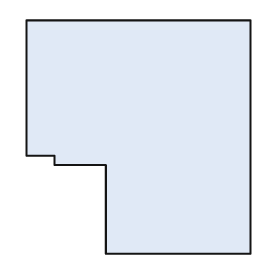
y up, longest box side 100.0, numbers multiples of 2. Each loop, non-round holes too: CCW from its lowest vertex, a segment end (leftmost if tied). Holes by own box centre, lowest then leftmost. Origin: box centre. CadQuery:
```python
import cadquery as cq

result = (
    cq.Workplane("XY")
    .moveTo(-14.0, -50.0)
    .lineTo(48.0, -50.0)
    .lineTo(48.0, 50.0)
    .lineTo(-48.0, 50.0)
    .lineTo(-48.0, -8.0)
    .lineTo(-36.0, -8.0)
    .lineTo(-36.0, -12.0)
    .lineTo(-14.0, -12.0)
    .close()
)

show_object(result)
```